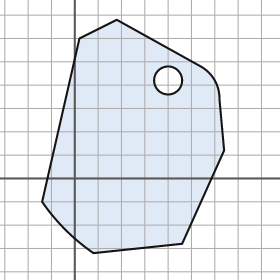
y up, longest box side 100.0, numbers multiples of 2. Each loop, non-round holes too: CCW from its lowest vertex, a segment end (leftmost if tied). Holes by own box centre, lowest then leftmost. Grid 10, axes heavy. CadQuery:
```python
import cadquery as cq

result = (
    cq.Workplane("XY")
    .moveTo(8.0, -32.0)
    .lineTo(46.0, -28.0)
    .lineTo(64.0, 12.0)
    .lineTo(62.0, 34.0)
    .threePointArc((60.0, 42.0), (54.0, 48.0))
    .lineTo(18.0, 68.0)
    .lineTo(2.0, 60.0)
    .lineTo(-14.0, -10.0)
    .threePointArc((-4.0, -22.0), (8.0, -32.0))
    .close()
    .moveTo(40.0, 42.0)
    .circle(6.0)
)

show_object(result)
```